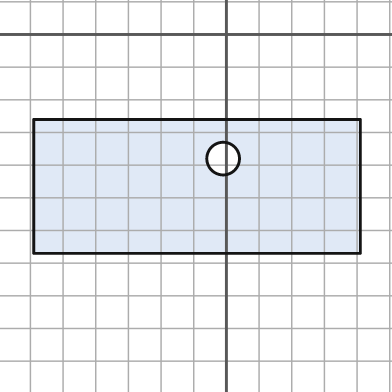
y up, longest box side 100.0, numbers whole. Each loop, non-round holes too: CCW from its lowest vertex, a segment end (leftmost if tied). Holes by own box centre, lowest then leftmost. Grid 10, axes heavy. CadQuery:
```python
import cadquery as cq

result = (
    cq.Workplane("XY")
    .moveTo(-59.0, -67.0)
    .lineTo(41.0, -67.0)
    .lineTo(41.0, -26.0)
    .lineTo(-59.0, -26.0)
    .close()
    .moveTo(-1.0, -38.0)
    .circle(5.0)
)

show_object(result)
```